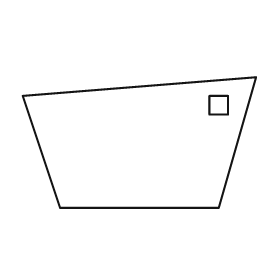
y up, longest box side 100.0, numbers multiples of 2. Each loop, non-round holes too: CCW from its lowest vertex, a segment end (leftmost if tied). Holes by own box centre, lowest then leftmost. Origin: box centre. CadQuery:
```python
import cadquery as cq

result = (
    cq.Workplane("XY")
    .moveTo(-34.0, -28.0)
    .lineTo(34.0, -28.0)
    .lineTo(50.0, 28.0)
    .lineTo(-50.0, 20.0)
    .close()
    .moveTo(30.0, 12.0)
    .lineTo(38.0, 12.0)
    .lineTo(38.0, 20.0)
    .lineTo(30.0, 20.0)
    .close()
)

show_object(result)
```